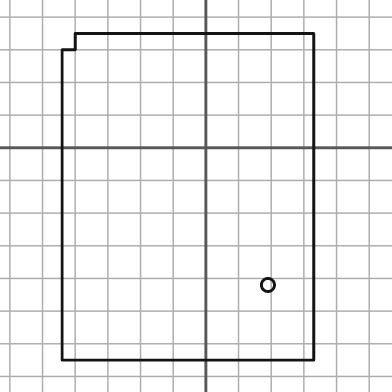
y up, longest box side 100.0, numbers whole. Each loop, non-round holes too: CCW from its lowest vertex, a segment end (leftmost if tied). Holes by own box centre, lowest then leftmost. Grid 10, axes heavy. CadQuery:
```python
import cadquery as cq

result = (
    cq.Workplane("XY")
    .moveTo(-44.0, -65.0)
    .lineTo(33.0, -65.0)
    .lineTo(33.0, 35.0)
    .lineTo(-40.0, 35.0)
    .lineTo(-40.0, 30.0)
    .lineTo(-44.0, 30.0)
    .close()
    .moveTo(19.0, -42.0)
    .circle(2.0)
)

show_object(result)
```